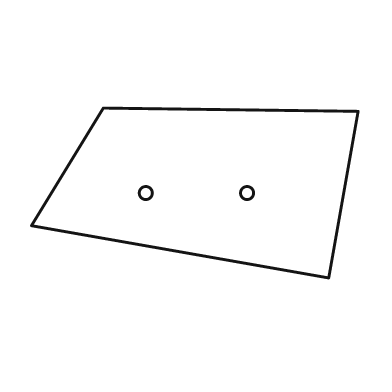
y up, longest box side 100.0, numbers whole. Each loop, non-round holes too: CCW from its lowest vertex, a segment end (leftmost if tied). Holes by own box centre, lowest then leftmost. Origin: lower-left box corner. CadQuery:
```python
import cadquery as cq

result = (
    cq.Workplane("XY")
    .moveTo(91.0, 0.0)
    .lineTo(100.0, 51.0)
    .lineTo(22.0, 52.0)
    .lineTo(0.0, 16.0)
    .close()
    .moveTo(35.0, 26.0)
    .circle(2.0)
    .moveTo(66.0, 26.0)
    .circle(2.0)
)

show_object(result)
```